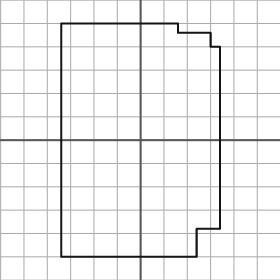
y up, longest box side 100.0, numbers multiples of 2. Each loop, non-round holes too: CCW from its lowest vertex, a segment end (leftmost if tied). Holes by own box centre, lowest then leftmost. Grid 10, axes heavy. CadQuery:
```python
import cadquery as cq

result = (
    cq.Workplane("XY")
    .moveTo(-34.0, -50.0)
    .lineTo(24.0, -50.0)
    .lineTo(24.0, -38.0)
    .lineTo(34.0, -38.0)
    .lineTo(34.0, 40.0)
    .lineTo(30.0, 40.0)
    .lineTo(30.0, 46.0)
    .lineTo(16.0, 46.0)
    .lineTo(16.0, 50.0)
    .lineTo(-34.0, 50.0)
    .close()
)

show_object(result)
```